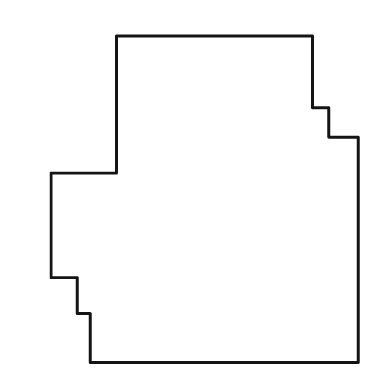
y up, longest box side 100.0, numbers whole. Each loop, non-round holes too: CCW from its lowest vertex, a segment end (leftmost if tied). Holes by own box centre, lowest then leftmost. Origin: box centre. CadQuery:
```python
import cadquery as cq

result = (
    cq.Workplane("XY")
    .moveTo(-35.0, -50.0)
    .lineTo(47.0, -50.0)
    .lineTo(47.0, 19.0)
    .lineTo(38.0, 19.0)
    .lineTo(38.0, 28.0)
    .lineTo(33.0, 28.0)
    .lineTo(33.0, 50.0)
    .lineTo(-27.0, 50.0)
    .lineTo(-27.0, 8.0)
    .lineTo(-47.0, 8.0)
    .lineTo(-47.0, -24.0)
    .lineTo(-39.0, -24.0)
    .lineTo(-39.0, -35.0)
    .lineTo(-35.0, -35.0)
    .close()
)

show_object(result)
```